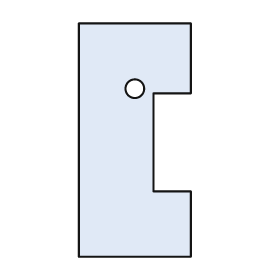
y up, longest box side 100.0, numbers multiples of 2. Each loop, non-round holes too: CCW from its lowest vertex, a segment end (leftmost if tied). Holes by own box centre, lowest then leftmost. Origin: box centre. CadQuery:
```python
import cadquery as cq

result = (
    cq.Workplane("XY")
    .moveTo(-24.0, -50.0)
    .lineTo(24.0, -50.0)
    .lineTo(24.0, -22.0)
    .lineTo(8.0, -22.0)
    .lineTo(8.0, 20.0)
    .lineTo(24.0, 20.0)
    .lineTo(24.0, 50.0)
    .lineTo(-24.0, 50.0)
    .close()
    .moveTo(0.0, 22.0)
    .circle(4.0)
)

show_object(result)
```